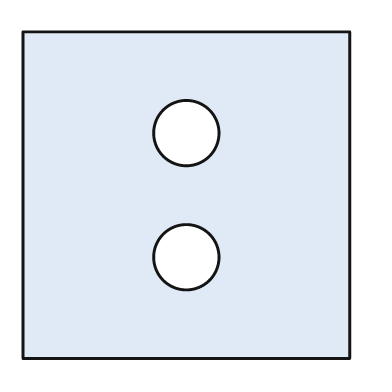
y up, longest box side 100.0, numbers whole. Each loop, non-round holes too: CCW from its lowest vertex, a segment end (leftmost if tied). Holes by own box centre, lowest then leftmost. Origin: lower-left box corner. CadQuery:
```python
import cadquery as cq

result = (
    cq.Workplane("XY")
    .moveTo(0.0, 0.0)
    .lineTo(100.0, 0.0)
    .lineTo(100.0, 100.0)
    .lineTo(0.0, 100.0)
    .close()
    .moveTo(50.0, 31.0)
    .circle(10.0)
    .moveTo(50.0, 69.0)
    .circle(10.0)
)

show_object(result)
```